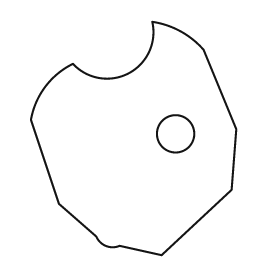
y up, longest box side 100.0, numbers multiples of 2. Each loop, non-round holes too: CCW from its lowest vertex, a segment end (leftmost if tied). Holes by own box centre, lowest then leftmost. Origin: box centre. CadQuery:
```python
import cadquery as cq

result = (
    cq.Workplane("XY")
    .moveTo(12.0, -50.0)
    .lineTo(42.0, -22.0)
    .lineTo(44.0, 4.0)
    .lineTo(30.0, 38.0)
    .threePointArc((20.0, 46.0), (8.0, 50.0))
    .threePointArc((-2.0, 28.0), (-26.0, 32.0))
    .threePointArc((-38.0, 22.0), (-44.0, 8.0))
    .lineTo(-32.0, -28.0)
    .lineTo(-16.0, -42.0)
    .threePointArc((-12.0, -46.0), (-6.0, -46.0))
    .close()
    .moveTo(18.0, 2.0)
    .circle(8.0)
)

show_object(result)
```